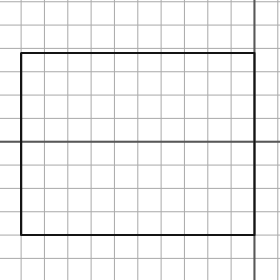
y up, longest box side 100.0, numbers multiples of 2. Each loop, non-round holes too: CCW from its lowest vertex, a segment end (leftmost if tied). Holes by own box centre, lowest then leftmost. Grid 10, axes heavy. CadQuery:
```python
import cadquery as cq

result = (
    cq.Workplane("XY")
    .moveTo(-100.0, -40.0)
    .lineTo(0.0, -40.0)
    .lineTo(0.0, 38.0)
    .lineTo(-100.0, 38.0)
    .close()
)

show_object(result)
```